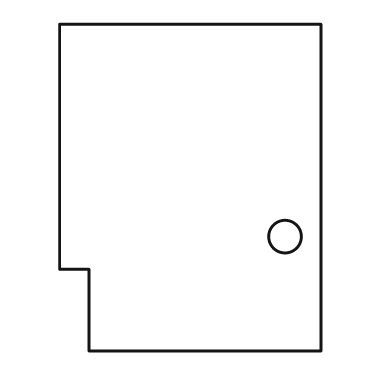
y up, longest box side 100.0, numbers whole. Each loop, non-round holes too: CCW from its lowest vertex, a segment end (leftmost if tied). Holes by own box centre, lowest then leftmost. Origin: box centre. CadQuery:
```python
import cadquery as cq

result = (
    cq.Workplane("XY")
    .moveTo(-31.0, -50.0)
    .lineTo(40.0, -50.0)
    .lineTo(40.0, 50.0)
    .lineTo(-40.0, 50.0)
    .lineTo(-40.0, -25.0)
    .lineTo(-31.0, -25.0)
    .close()
    .moveTo(29.0, -15.0)
    .circle(5.0)
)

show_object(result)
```